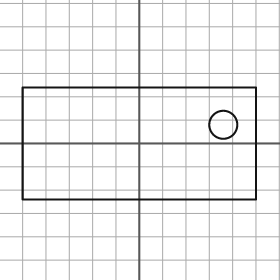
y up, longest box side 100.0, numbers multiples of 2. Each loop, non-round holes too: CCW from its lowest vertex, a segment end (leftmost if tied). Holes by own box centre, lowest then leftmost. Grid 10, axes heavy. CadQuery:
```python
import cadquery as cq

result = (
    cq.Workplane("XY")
    .moveTo(-50.0, -24.0)
    .lineTo(50.0, -24.0)
    .lineTo(50.0, 24.0)
    .lineTo(-50.0, 24.0)
    .close()
    .moveTo(36.0, 8.0)
    .circle(6.0)
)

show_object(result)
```